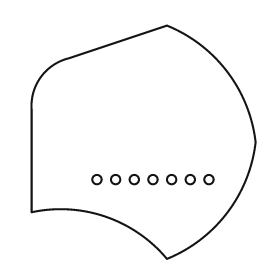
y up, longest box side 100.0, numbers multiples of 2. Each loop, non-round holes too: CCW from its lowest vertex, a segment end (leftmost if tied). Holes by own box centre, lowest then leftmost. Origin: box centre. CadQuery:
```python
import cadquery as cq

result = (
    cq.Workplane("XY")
    .moveTo(10.0, -50.0)
    .threePointArc((36.0, -30.0), (48.0, 0.0))
    .threePointArc((36.0, 30.0), (10.0, 50.0))
    .lineTo(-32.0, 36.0)
    .threePointArc((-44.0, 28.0), (-48.0, 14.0))
    .lineTo(-48.0, -30.0)
    .threePointArc((-16.0, -32.0), (10.0, -50.0))
    .close()
    .moveTo(-20.0, -16.0)
    .circle(2.0)
    .moveTo(-12.0, -16.0)
    .circle(2.0)
    .moveTo(-4.0, -16.0)
    .circle(2.0)
    .moveTo(4.0, -16.0)
    .circle(2.0)
    .moveTo(12.0, -16.0)
    .circle(2.0)
    .moveTo(20.0, -16.0)
    .circle(2.0)
    .moveTo(28.0, -16.0)
    .circle(2.0)
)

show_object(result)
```